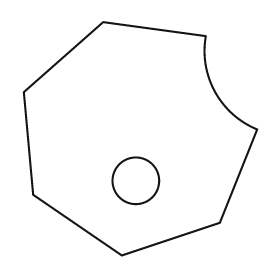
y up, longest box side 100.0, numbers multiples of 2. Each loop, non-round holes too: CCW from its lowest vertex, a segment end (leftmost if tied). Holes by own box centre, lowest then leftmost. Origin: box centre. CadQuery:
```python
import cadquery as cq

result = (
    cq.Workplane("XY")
    .moveTo(-8.0, -50.0)
    .lineTo(34.0, -36.0)
    .lineTo(50.0, 4.0)
    .threePointArc((32.0, 20.0), (28.0, 44.0))
    .lineTo(-16.0, 50.0)
    .lineTo(-50.0, 20.0)
    .lineTo(-46.0, -24.0)
    .close()
    .moveTo(-2.0, -18.0)
    .circle(10.0)
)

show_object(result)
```